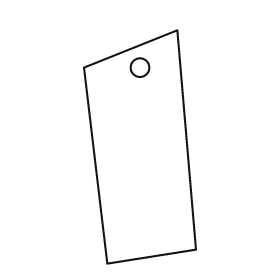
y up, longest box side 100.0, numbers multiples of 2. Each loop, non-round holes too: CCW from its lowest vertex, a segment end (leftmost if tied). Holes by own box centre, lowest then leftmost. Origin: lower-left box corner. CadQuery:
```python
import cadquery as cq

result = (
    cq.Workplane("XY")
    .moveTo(10.0, 0.0)
    .lineTo(48.0, 6.0)
    .lineTo(40.0, 100.0)
    .lineTo(0.0, 84.0)
    .close()
    .moveTo(24.0, 84.0)
    .circle(4.0)
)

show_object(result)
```